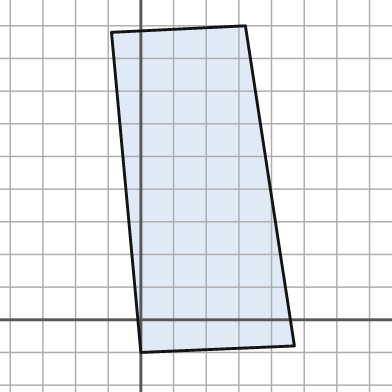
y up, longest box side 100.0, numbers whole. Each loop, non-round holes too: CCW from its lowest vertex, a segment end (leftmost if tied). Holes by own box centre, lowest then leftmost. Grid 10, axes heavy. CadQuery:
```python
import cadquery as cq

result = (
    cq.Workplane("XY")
    .moveTo(0.0, -10.0)
    .lineTo(47.0, -8.0)
    .lineTo(32.0, 90.0)
    .lineTo(-9.0, 88.0)
    .close()
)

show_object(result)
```